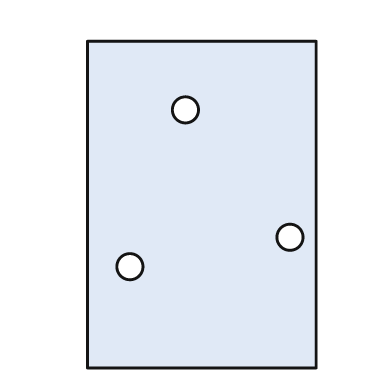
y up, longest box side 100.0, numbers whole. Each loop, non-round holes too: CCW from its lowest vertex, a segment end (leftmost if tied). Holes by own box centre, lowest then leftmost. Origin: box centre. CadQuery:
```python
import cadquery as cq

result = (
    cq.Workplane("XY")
    .moveTo(-35.0, -50.0)
    .lineTo(35.0, -50.0)
    .lineTo(35.0, 50.0)
    .lineTo(-35.0, 50.0)
    .close()
    .moveTo(-22.0, -19.0)
    .circle(4.0)
    .moveTo(27.0, -10.0)
    .circle(4.0)
    .moveTo(-5.0, 29.0)
    .circle(4.0)
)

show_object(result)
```